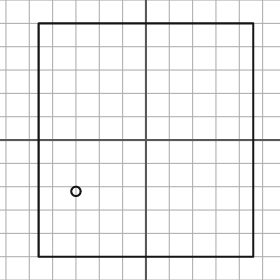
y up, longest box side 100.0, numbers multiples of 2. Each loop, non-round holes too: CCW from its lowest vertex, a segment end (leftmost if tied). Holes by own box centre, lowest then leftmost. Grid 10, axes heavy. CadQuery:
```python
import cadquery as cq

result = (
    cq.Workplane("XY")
    .moveTo(-46.0, -50.0)
    .lineTo(46.0, -50.0)
    .lineTo(46.0, 50.0)
    .lineTo(-46.0, 50.0)
    .close()
    .moveTo(-30.0, -22.0)
    .circle(2.0)
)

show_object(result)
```